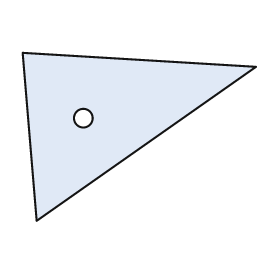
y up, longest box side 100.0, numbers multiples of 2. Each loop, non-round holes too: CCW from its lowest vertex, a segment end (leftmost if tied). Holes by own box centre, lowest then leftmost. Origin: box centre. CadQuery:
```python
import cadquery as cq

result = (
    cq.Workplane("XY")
    .moveTo(-44.0, -36.0)
    .lineTo(50.0, 30.0)
    .lineTo(-50.0, 36.0)
    .close()
    .moveTo(-24.0, 8.0)
    .circle(4.0)
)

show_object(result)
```